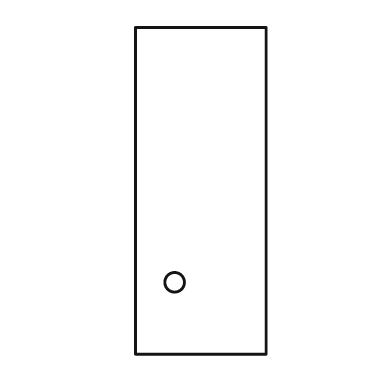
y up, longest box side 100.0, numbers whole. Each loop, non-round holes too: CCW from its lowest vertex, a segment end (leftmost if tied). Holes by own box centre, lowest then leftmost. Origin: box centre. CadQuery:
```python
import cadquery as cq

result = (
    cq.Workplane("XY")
    .moveTo(-20.0, -50.0)
    .lineTo(20.0, -50.0)
    .lineTo(20.0, 50.0)
    .lineTo(-20.0, 50.0)
    .close()
    .moveTo(-8.0, -28.0)
    .circle(3.0)
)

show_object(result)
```